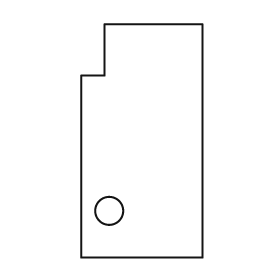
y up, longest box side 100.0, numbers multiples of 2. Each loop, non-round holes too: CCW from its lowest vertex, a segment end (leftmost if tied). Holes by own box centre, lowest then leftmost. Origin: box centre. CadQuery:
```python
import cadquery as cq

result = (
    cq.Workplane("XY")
    .moveTo(-26.0, -50.0)
    .lineTo(26.0, -50.0)
    .lineTo(26.0, 50.0)
    .lineTo(-16.0, 50.0)
    .lineTo(-16.0, 28.0)
    .lineTo(-26.0, 28.0)
    .close()
    .moveTo(-14.0, -30.0)
    .circle(6.0)
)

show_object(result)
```